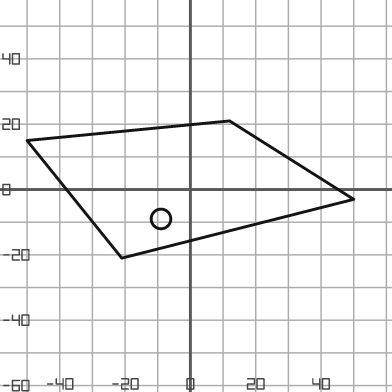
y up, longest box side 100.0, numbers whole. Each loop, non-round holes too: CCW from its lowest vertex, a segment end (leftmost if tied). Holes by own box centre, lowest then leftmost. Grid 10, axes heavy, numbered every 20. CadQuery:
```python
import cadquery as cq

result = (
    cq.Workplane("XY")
    .moveTo(-21.0, -21.0)
    .lineTo(50.0, -3.0)
    .lineTo(12.0, 21.0)
    .lineTo(-50.0, 15.0)
    .close()
    .moveTo(-9.0, -9.0)
    .circle(3.0)
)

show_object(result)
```